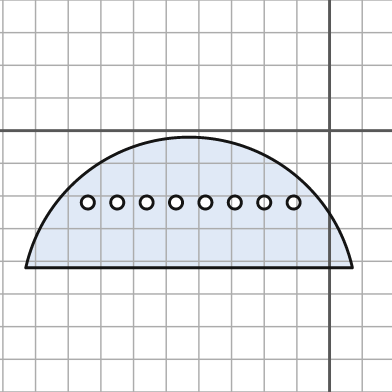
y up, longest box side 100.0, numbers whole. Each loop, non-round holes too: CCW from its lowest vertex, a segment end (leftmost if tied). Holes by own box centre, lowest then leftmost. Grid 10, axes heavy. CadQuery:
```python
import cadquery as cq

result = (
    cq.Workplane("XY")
    .moveTo(-93.0, -42.0)
    .lineTo(7.0, -42.0)
    .threePointArc((-43.0, -2.0), (-93.0, -42.0))
    .close()
    .moveTo(-74.0, -22.0)
    .circle(2.0)
    .moveTo(-65.0, -22.0)
    .circle(2.0)
    .moveTo(-56.0, -22.0)
    .circle(2.0)
    .moveTo(-47.0, -22.0)
    .circle(2.0)
    .moveTo(-38.0, -22.0)
    .circle(2.0)
    .moveTo(-29.0, -22.0)
    .circle(2.0)
    .moveTo(-20.0, -22.0)
    .circle(2.0)
    .moveTo(-11.0, -22.0)
    .circle(2.0)
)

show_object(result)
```